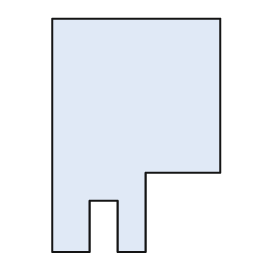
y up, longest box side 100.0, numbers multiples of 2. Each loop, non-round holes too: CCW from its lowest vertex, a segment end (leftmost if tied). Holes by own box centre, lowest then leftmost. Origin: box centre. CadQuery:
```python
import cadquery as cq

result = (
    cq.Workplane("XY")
    .moveTo(-36.0, -50.0)
    .lineTo(-20.0, -50.0)
    .lineTo(-20.0, -28.0)
    .lineTo(-8.0, -28.0)
    .lineTo(-8.0, -50.0)
    .lineTo(4.0, -50.0)
    .lineTo(4.0, -16.0)
    .lineTo(36.0, -16.0)
    .lineTo(36.0, 50.0)
    .lineTo(-36.0, 50.0)
    .close()
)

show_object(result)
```